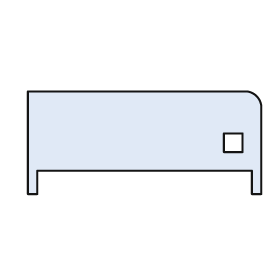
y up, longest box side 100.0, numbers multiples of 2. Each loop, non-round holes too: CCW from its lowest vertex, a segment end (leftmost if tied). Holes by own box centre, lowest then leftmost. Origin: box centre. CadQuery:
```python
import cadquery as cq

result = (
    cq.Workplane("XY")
    .moveTo(-50.0, -22.0)
    .lineTo(-46.0, -22.0)
    .lineTo(-46.0, -12.0)
    .lineTo(46.0, -12.0)
    .lineTo(46.0, -22.0)
    .lineTo(50.0, -22.0)
    .lineTo(50.0, 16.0)
    .threePointArc((48.0, 20.0), (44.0, 22.0))
    .lineTo(-50.0, 22.0)
    .close()
    .moveTo(34.0, -4.0)
    .lineTo(42.0, -4.0)
    .lineTo(42.0, 4.0)
    .lineTo(34.0, 4.0)
    .close()
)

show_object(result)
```